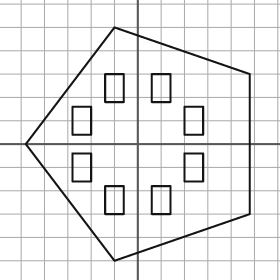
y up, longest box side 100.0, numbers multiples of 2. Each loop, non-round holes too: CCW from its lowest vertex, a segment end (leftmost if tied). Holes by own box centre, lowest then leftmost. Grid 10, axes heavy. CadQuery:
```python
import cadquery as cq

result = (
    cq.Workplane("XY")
    .moveTo(-10.0, -50.0)
    .lineTo(48.0, -30.0)
    .lineTo(48.0, 30.0)
    .lineTo(-10.0, 50.0)
    .lineTo(-48.0, 0.0)
    .close()
    .moveTo(-14.0, -30.0)
    .lineTo(-6.0, -30.0)
    .lineTo(-6.0, -18.0)
    .lineTo(-14.0, -18.0)
    .close()
    .moveTo(6.0, -30.0)
    .lineTo(14.0, -30.0)
    .lineTo(14.0, -18.0)
    .lineTo(6.0, -18.0)
    .close()
    .moveTo(-28.0, -16.0)
    .lineTo(-20.0, -16.0)
    .lineTo(-20.0, -4.0)
    .lineTo(-28.0, -4.0)
    .close()
    .moveTo(20.0, -16.0)
    .lineTo(28.0, -16.0)
    .lineTo(28.0, -4.0)
    .lineTo(20.0, -4.0)
    .close()
    .moveTo(-28.0, 4.0)
    .lineTo(-20.0, 4.0)
    .lineTo(-20.0, 16.0)
    .lineTo(-28.0, 16.0)
    .close()
    .moveTo(20.0, 4.0)
    .lineTo(28.0, 4.0)
    .lineTo(28.0, 16.0)
    .lineTo(20.0, 16.0)
    .close()
    .moveTo(-14.0, 18.0)
    .lineTo(-6.0, 18.0)
    .lineTo(-6.0, 30.0)
    .lineTo(-14.0, 30.0)
    .close()
    .moveTo(6.0, 18.0)
    .lineTo(14.0, 18.0)
    .lineTo(14.0, 30.0)
    .lineTo(6.0, 30.0)
    .close()
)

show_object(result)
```